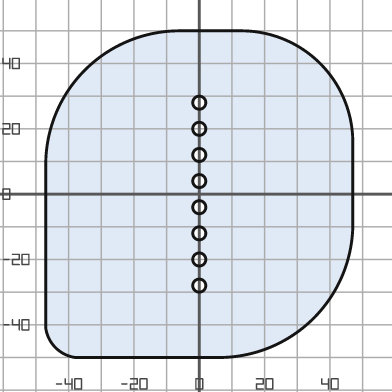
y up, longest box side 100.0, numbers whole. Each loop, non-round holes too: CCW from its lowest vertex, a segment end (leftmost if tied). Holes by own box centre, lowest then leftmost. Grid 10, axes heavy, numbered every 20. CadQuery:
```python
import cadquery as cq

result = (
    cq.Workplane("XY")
    .moveTo(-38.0, -50.0)
    .lineTo(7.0, -50.0)
    .threePointArc((35.0, -38.0), (47.0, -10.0))
    .lineTo(47.0, 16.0)
    .threePointArc((37.0, 40.0), (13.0, 50.0))
    .lineTo(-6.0, 50.0)
    .threePointArc((-35.0, 38.0), (-47.0, 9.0))
    .lineTo(-47.0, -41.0)
    .threePointArc((-44.0, -47.0), (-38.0, -50.0))
    .close()
    .moveTo(0.0, -28.0)
    .circle(2.0)
    .moveTo(0.0, -20.0)
    .circle(2.0)
    .moveTo(0.0, -12.0)
    .circle(2.0)
    .moveTo(0.0, -4.0)
    .circle(2.0)
    .moveTo(0.0, 4.0)
    .circle(2.0)
    .moveTo(0.0, 12.0)
    .circle(2.0)
    .moveTo(0.0, 20.0)
    .circle(2.0)
    .moveTo(0.0, 28.0)
    .circle(2.0)
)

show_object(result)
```